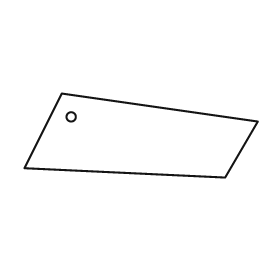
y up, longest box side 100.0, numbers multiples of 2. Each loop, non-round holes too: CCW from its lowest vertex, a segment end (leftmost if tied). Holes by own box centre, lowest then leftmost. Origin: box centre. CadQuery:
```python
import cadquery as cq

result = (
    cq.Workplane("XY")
    .moveTo(36.0, -18.0)
    .lineTo(50.0, 6.0)
    .lineTo(-34.0, 18.0)
    .lineTo(-50.0, -14.0)
    .close()
    .moveTo(-30.0, 8.0)
    .circle(2.0)
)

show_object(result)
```